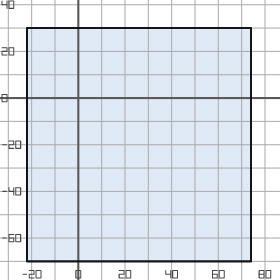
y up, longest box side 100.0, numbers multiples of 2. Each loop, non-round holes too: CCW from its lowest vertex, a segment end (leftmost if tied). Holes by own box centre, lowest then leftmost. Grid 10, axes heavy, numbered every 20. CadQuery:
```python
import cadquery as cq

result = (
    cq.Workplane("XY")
    .moveTo(-22.0, -70.0)
    .lineTo(74.0, -70.0)
    .lineTo(74.0, 30.0)
    .lineTo(-22.0, 30.0)
    .close()
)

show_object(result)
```